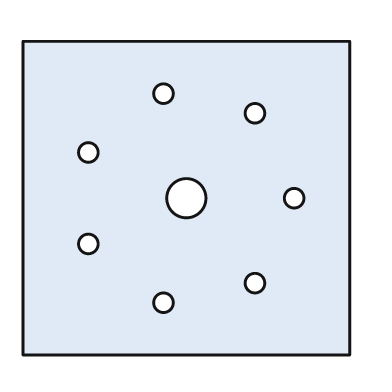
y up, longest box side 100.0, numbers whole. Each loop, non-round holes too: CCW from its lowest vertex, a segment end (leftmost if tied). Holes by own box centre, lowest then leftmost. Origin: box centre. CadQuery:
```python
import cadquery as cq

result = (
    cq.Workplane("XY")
    .moveTo(-50.0, -48.0)
    .lineTo(50.0, -48.0)
    .lineTo(50.0, 48.0)
    .lineTo(-50.0, 48.0)
    .close()
    .moveTo(-7.0, -32.0)
    .circle(3.0)
    .moveTo(21.0, -26.0)
    .circle(3.0)
    .moveTo(-30.0, -14.0)
    .circle(3.0)
    .moveTo(0.0, 0.0)
    .circle(6.0)
    .moveTo(33.0, 0.0)
    .circle(3.0)
    .moveTo(-30.0, 14.0)
    .circle(3.0)
    .moveTo(21.0, 26.0)
    .circle(3.0)
    .moveTo(-7.0, 32.0)
    .circle(3.0)
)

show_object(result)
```